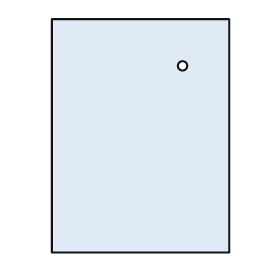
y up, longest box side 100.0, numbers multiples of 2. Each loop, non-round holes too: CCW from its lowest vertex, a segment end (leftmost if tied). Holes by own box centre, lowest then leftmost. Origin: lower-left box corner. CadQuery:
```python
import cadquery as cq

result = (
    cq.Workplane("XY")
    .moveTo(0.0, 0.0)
    .lineTo(76.0, 0.0)
    .lineTo(76.0, 100.0)
    .lineTo(0.0, 100.0)
    .close()
    .moveTo(56.0, 80.0)
    .circle(2.0)
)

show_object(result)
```